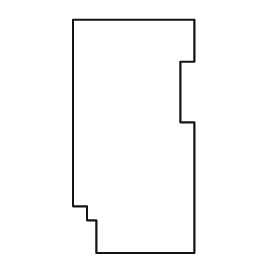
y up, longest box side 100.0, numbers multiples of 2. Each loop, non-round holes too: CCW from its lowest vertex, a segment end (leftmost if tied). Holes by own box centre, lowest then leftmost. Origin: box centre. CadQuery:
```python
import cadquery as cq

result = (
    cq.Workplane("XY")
    .moveTo(-16.0, -50.0)
    .lineTo(26.0, -50.0)
    .lineTo(26.0, 6.0)
    .lineTo(20.0, 6.0)
    .lineTo(20.0, 32.0)
    .lineTo(26.0, 32.0)
    .lineTo(26.0, 50.0)
    .lineTo(-26.0, 50.0)
    .lineTo(-26.0, -30.0)
    .lineTo(-20.0, -30.0)
    .lineTo(-20.0, -36.0)
    .lineTo(-16.0, -36.0)
    .close()
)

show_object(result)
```